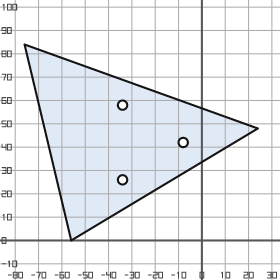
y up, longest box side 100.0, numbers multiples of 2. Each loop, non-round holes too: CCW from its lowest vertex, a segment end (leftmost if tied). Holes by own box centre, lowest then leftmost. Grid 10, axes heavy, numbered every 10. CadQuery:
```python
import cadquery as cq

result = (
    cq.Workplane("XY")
    .moveTo(-56.0, 0.0)
    .lineTo(24.0, 48.0)
    .lineTo(-76.0, 84.0)
    .close()
    .moveTo(-34.0, 26.0)
    .circle(2.0)
    .moveTo(-8.0, 42.0)
    .circle(2.0)
    .moveTo(-34.0, 58.0)
    .circle(2.0)
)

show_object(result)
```